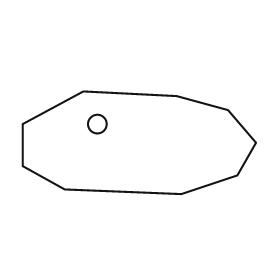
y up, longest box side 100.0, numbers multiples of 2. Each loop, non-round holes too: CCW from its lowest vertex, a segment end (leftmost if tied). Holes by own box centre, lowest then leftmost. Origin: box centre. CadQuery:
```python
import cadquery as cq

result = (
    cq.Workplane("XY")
    .moveTo(18.0, -22.0)
    .lineTo(42.0, -14.0)
    .lineTo(50.0, 0.0)
    .lineTo(38.0, 14.0)
    .lineTo(16.0, 20.0)
    .lineTo(-24.0, 22.0)
    .lineTo(-50.0, 8.0)
    .lineTo(-50.0, -10.0)
    .lineTo(-32.0, -20.0)
    .close()
    .moveTo(-18.0, 8.0)
    .circle(4.0)
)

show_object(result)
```